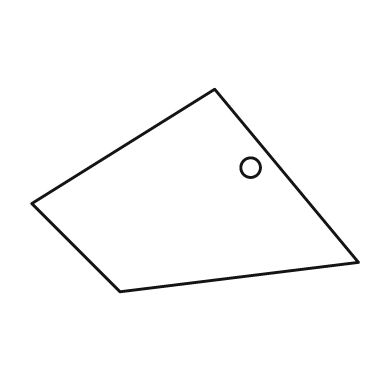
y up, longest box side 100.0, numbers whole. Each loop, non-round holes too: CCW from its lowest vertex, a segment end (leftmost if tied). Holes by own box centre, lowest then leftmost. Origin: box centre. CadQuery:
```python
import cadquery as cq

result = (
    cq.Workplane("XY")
    .moveTo(-23.0, -31.0)
    .lineTo(50.0, -22.0)
    .lineTo(6.0, 31.0)
    .lineTo(-50.0, -4.0)
    .close()
    .moveTo(17.0, 7.0)
    .circle(3.0)
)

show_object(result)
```